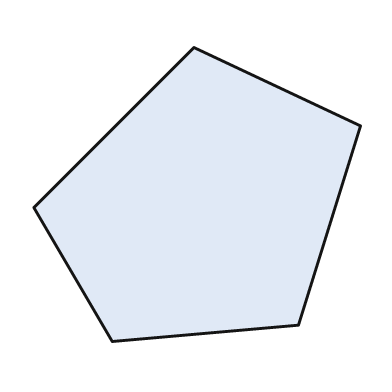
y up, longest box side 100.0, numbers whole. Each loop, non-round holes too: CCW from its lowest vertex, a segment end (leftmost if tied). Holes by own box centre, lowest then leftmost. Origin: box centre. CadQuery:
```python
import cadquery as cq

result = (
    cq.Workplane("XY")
    .moveTo(-26.0, -45.0)
    .lineTo(31.0, -40.0)
    .lineTo(50.0, 21.0)
    .lineTo(-1.0, 45.0)
    .lineTo(-50.0, -4.0)
    .close()
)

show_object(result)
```